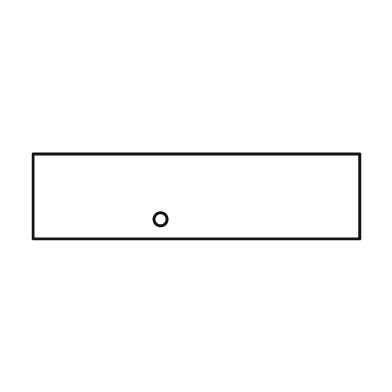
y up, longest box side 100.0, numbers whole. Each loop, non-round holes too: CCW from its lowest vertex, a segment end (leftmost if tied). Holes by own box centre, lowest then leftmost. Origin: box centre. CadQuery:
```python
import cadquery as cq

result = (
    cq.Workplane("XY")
    .moveTo(-50.0, -13.0)
    .lineTo(50.0, -13.0)
    .lineTo(50.0, 13.0)
    .lineTo(-50.0, 13.0)
    .close()
    .moveTo(-11.0, -7.0)
    .circle(2.0)
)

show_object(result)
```